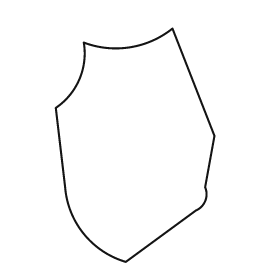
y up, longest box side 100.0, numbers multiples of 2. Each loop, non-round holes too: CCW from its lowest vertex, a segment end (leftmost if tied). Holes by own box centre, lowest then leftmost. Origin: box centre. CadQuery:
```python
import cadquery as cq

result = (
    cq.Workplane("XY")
    .moveTo(-4.0, -50.0)
    .lineTo(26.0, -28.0)
    .threePointArc((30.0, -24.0), (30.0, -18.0))
    .lineTo(34.0, 4.0)
    .lineTo(16.0, 50.0)
    .threePointArc((-2.0, 42.0), (-22.0, 44.0))
    .threePointArc((-24.0, 28.0), (-34.0, 16.0))
    .lineTo(-30.0, -18.0)
    .threePointArc((-22.0, -38.0), (-4.0, -50.0))
    .close()
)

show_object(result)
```